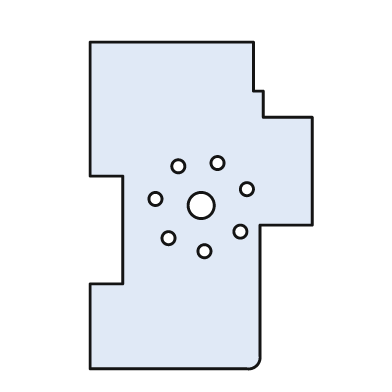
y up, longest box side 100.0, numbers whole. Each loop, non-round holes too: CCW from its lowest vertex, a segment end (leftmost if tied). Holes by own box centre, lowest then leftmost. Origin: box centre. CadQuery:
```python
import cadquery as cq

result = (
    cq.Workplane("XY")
    .moveTo(-34.0, -50.0)
    .lineTo(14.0, -50.0)
    .threePointArc((17.0, -49.0), (18.0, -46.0))
    .lineTo(18.0, -6.0)
    .lineTo(34.0, -6.0)
    .lineTo(34.0, 27.0)
    .lineTo(19.0, 27.0)
    .lineTo(19.0, 35.0)
    .lineTo(16.0, 35.0)
    .lineTo(16.0, 50.0)
    .lineTo(-34.0, 50.0)
    .lineTo(-34.0, 9.0)
    .lineTo(-24.0, 9.0)
    .lineTo(-24.0, -24.0)
    .lineTo(-34.0, -24.0)
    .close()
    .moveTo(1.0, -14.0)
    .circle(2.0)
    .moveTo(-10.0, -10.0)
    .circle(2.0)
    .moveTo(12.0, -8.0)
    .circle(2.0)
    .moveTo(0.0, 0.0)
    .circle(4.0)
    .moveTo(-14.0, 2.0)
    .circle(2.0)
    .moveTo(14.0, 5.0)
    .circle(2.0)
    .moveTo(-7.0, 12.0)
    .circle(2.0)
    .moveTo(5.0, 13.0)
    .circle(2.0)
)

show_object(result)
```